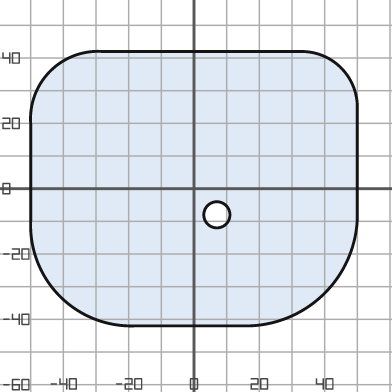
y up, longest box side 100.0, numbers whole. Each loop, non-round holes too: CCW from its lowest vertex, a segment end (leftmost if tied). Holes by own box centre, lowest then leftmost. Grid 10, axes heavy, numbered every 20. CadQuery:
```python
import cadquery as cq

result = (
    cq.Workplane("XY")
    .moveTo(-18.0, -42.0)
    .lineTo(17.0, -42.0)
    .threePointArc((40.0, -32.0), (50.0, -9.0))
    .lineTo(50.0, 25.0)
    .threePointArc((45.0, 37.0), (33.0, 42.0))
    .lineTo(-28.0, 42.0)
    .threePointArc((-44.0, 36.0), (-50.0, 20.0))
    .lineTo(-50.0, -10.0)
    .threePointArc((-41.0, -33.0), (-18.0, -42.0))
    .close()
    .moveTo(7.0, -8.0)
    .circle(4.0)
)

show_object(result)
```